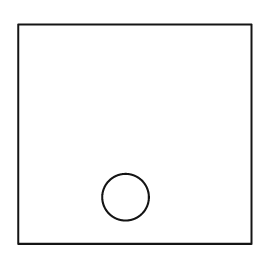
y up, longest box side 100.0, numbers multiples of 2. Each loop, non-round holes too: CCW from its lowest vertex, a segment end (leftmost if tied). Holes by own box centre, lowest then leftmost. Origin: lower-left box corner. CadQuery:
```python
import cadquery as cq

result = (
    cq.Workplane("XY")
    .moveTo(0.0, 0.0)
    .lineTo(100.0, 0.0)
    .lineTo(100.0, 94.0)
    .lineTo(0.0, 94.0)
    .close()
    .moveTo(46.0, 20.0)
    .circle(10.0)
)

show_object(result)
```